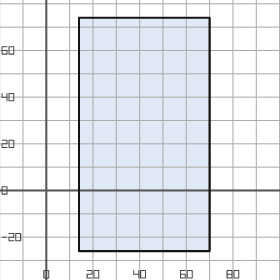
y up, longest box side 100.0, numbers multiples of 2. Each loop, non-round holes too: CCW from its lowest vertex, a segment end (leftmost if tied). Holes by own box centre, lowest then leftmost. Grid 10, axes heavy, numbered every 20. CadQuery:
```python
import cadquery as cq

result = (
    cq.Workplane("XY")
    .moveTo(14.0, -26.0)
    .lineTo(70.0, -26.0)
    .lineTo(70.0, 74.0)
    .lineTo(14.0, 74.0)
    .close()
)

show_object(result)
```